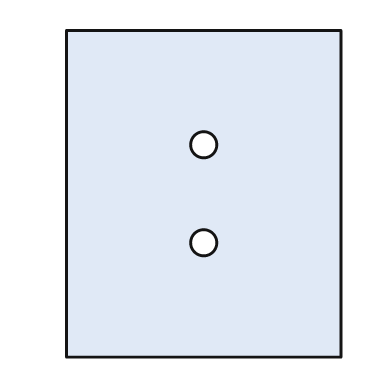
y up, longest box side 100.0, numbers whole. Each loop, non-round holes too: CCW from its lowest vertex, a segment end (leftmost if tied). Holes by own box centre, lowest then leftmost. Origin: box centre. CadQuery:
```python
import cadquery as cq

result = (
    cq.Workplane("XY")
    .moveTo(-42.0, -50.0)
    .lineTo(42.0, -50.0)
    .lineTo(42.0, 50.0)
    .lineTo(-42.0, 50.0)
    .close()
    .moveTo(0.0, -15.0)
    .circle(4.0)
    .moveTo(0.0, 15.0)
    .circle(4.0)
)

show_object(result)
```